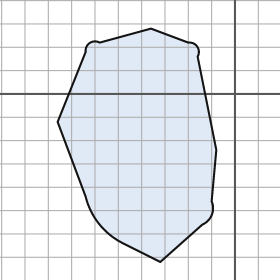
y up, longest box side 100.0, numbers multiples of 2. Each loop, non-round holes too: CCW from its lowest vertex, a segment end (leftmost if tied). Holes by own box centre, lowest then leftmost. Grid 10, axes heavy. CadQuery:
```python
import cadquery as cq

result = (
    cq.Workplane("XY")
    .moveTo(-32.0, -72.0)
    .lineTo(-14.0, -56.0)
    .threePointArc((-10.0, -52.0), (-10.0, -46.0))
    .lineTo(-8.0, -24.0)
    .lineTo(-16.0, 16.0)
    .threePointArc((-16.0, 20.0), (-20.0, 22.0))
    .lineTo(-36.0, 28.0)
    .lineTo(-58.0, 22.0)
    .threePointArc((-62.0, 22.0), (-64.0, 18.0))
    .lineTo(-76.0, -12.0)
    .lineTo(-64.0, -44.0)
    .threePointArc((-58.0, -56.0), (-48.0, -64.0))
    .close()
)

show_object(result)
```